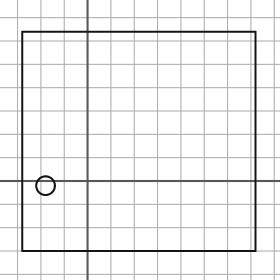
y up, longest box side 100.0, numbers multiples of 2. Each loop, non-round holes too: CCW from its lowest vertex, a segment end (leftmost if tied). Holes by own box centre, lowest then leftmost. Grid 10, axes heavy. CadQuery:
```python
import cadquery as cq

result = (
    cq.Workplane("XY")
    .moveTo(-28.0, -30.0)
    .lineTo(72.0, -30.0)
    .lineTo(72.0, 64.0)
    .lineTo(-28.0, 64.0)
    .close()
    .moveTo(-18.0, -2.0)
    .circle(4.0)
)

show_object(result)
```